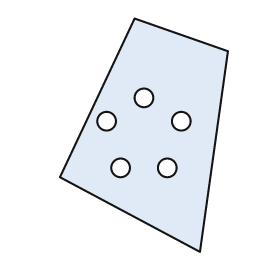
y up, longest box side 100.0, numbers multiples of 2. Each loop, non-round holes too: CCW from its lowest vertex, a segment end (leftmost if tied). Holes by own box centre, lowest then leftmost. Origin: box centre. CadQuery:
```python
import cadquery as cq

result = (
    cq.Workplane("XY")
    .moveTo(24.0, -50.0)
    .lineTo(36.0, 36.0)
    .lineTo(-4.0, 50.0)
    .lineTo(-36.0, -18.0)
    .close()
    .moveTo(-10.0, -14.0)
    .circle(4.0)
    .moveTo(10.0, -14.0)
    .circle(4.0)
    .moveTo(-16.0, 6.0)
    .circle(4.0)
    .moveTo(16.0, 6.0)
    .circle(4.0)
    .moveTo(0.0, 16.0)
    .circle(4.0)
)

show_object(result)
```